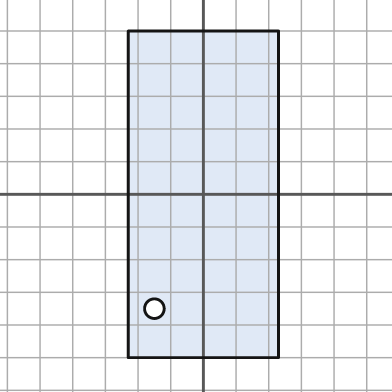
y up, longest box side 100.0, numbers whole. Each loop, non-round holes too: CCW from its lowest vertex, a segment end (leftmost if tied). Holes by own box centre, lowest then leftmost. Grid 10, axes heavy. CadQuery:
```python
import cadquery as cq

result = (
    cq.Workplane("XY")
    .moveTo(-23.0, -50.0)
    .lineTo(23.0, -50.0)
    .lineTo(23.0, 50.0)
    .lineTo(-23.0, 50.0)
    .close()
    .moveTo(-15.0, -35.0)
    .circle(3.0)
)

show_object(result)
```